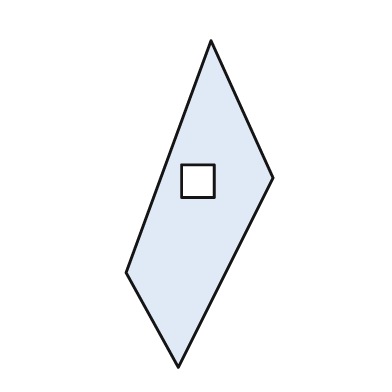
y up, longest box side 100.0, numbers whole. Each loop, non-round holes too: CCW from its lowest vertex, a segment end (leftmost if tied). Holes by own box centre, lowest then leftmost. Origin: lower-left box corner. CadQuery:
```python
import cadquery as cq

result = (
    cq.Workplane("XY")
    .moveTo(16.0, 0.0)
    .lineTo(45.0, 58.0)
    .lineTo(26.0, 100.0)
    .lineTo(0.0, 29.0)
    .close()
    .moveTo(17.0, 52.0)
    .lineTo(27.0, 52.0)
    .lineTo(27.0, 62.0)
    .lineTo(17.0, 62.0)
    .close()
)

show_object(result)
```